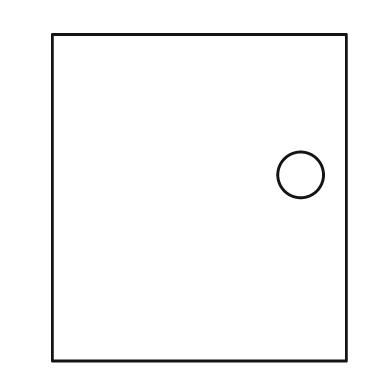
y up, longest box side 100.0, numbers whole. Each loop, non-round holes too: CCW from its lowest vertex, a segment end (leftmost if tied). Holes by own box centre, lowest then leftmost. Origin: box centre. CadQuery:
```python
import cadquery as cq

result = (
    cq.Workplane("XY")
    .moveTo(-45.0, -50.0)
    .lineTo(45.0, -50.0)
    .lineTo(45.0, 50.0)
    .lineTo(-45.0, 50.0)
    .close()
    .moveTo(31.0, 7.0)
    .circle(7.0)
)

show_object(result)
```